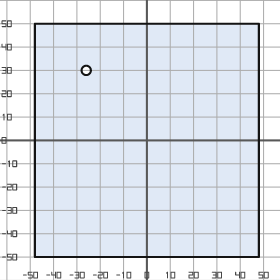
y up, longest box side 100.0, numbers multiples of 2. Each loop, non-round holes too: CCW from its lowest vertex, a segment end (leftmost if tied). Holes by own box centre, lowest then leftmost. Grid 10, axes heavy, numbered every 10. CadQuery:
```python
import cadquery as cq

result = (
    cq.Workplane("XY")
    .moveTo(-48.0, -50.0)
    .lineTo(48.0, -50.0)
    .lineTo(48.0, 50.0)
    .lineTo(-48.0, 50.0)
    .close()
    .moveTo(-26.0, 30.0)
    .circle(2.0)
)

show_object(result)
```